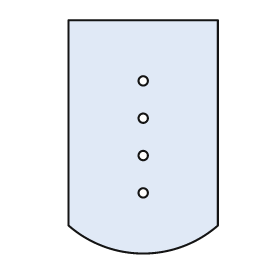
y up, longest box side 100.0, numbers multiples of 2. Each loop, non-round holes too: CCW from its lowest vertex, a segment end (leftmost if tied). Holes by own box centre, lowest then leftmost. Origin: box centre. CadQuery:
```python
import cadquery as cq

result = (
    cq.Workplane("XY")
    .moveTo(-32.0, -38.0)
    .threePointArc((0.0, -50.0), (32.0, -38.0))
    .lineTo(32.0, 50.0)
    .lineTo(-32.0, 50.0)
    .close()
    .moveTo(0.0, -24.0)
    .circle(2.0)
    .moveTo(0.0, -8.0)
    .circle(2.0)
    .moveTo(0.0, 8.0)
    .circle(2.0)
    .moveTo(0.0, 24.0)
    .circle(2.0)
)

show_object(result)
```